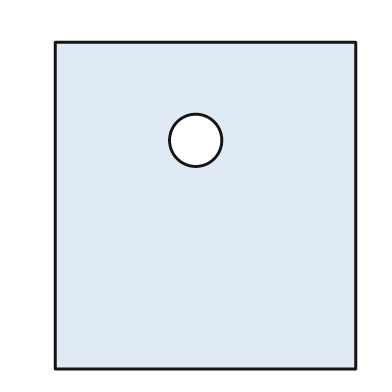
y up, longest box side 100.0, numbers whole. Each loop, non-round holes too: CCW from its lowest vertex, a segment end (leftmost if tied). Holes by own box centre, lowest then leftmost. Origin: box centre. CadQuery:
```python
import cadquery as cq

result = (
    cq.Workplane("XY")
    .moveTo(-46.0, -50.0)
    .lineTo(46.0, -50.0)
    .lineTo(46.0, 50.0)
    .lineTo(-46.0, 50.0)
    .close()
    .moveTo(-3.0, 20.0)
    .circle(8.0)
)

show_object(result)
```